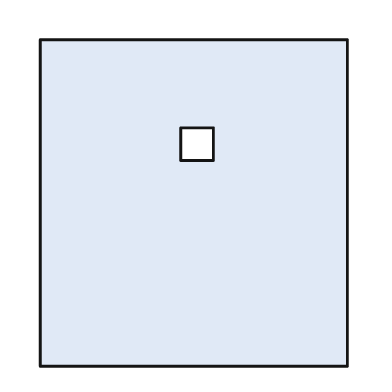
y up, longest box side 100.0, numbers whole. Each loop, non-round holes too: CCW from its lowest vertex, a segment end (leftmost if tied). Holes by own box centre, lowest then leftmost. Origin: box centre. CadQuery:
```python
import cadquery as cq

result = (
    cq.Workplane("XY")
    .moveTo(-47.0, -50.0)
    .lineTo(47.0, -50.0)
    .lineTo(47.0, 50.0)
    .lineTo(-47.0, 50.0)
    .close()
    .moveTo(-4.0, 13.0)
    .lineTo(6.0, 13.0)
    .lineTo(6.0, 23.0)
    .lineTo(-4.0, 23.0)
    .close()
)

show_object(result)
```